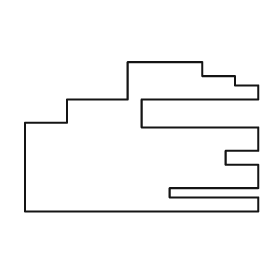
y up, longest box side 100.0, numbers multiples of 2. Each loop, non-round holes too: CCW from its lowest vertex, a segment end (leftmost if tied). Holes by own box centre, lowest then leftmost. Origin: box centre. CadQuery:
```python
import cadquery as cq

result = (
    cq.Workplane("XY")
    .moveTo(-50.0, -32.0)
    .lineTo(50.0, -32.0)
    .lineTo(50.0, -26.0)
    .lineTo(12.0, -26.0)
    .lineTo(12.0, -22.0)
    .lineTo(50.0, -22.0)
    .lineTo(50.0, -12.0)
    .lineTo(36.0, -12.0)
    .lineTo(36.0, -6.0)
    .lineTo(50.0, -6.0)
    .lineTo(50.0, 4.0)
    .lineTo(0.0, 4.0)
    .lineTo(0.0, 16.0)
    .lineTo(50.0, 16.0)
    .lineTo(50.0, 22.0)
    .lineTo(40.0, 22.0)
    .lineTo(40.0, 26.0)
    .lineTo(26.0, 26.0)
    .lineTo(26.0, 32.0)
    .lineTo(-6.0, 32.0)
    .lineTo(-6.0, 16.0)
    .lineTo(-32.0, 16.0)
    .lineTo(-32.0, 6.0)
    .lineTo(-50.0, 6.0)
    .close()
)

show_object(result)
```